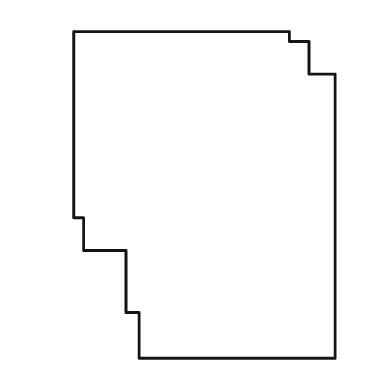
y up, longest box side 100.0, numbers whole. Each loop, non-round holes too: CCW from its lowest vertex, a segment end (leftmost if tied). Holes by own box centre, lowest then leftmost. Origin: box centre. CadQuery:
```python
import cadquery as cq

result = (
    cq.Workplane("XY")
    .moveTo(-20.0, -50.0)
    .lineTo(40.0, -50.0)
    .lineTo(40.0, 37.0)
    .lineTo(32.0, 37.0)
    .lineTo(32.0, 47.0)
    .lineTo(26.0, 47.0)
    .lineTo(26.0, 50.0)
    .lineTo(-40.0, 50.0)
    .lineTo(-40.0, -7.0)
    .lineTo(-37.0, -7.0)
    .lineTo(-37.0, -17.0)
    .lineTo(-24.0, -17.0)
    .lineTo(-24.0, -36.0)
    .lineTo(-20.0, -36.0)
    .close()
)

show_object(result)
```